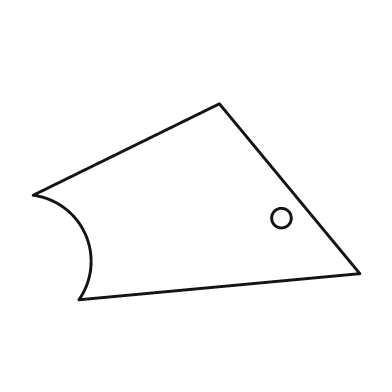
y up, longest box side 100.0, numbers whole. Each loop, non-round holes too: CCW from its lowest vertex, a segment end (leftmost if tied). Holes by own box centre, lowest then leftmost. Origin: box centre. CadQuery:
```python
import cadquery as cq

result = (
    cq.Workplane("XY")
    .moveTo(-36.0, -30.0)
    .lineTo(50.0, -22.0)
    .lineTo(7.0, 30.0)
    .lineTo(-50.0, 2.0)
    .threePointArc((-34.0, -10.0), (-36.0, -30.0))
    .close()
    .moveTo(26.0, -5.0)
    .circle(3.0)
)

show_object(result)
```